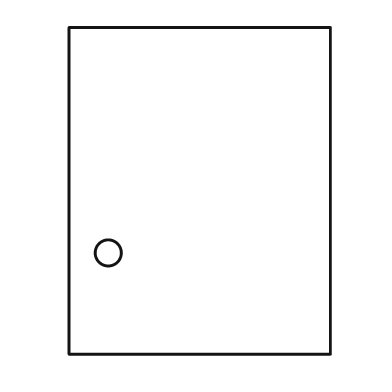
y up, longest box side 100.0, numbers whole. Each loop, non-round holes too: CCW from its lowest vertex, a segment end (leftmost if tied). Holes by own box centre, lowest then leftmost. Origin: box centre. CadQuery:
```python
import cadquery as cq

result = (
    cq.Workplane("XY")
    .moveTo(-40.0, -50.0)
    .lineTo(40.0, -50.0)
    .lineTo(40.0, 50.0)
    .lineTo(-40.0, 50.0)
    .close()
    .moveTo(-28.0, -19.0)
    .circle(4.0)
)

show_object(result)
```